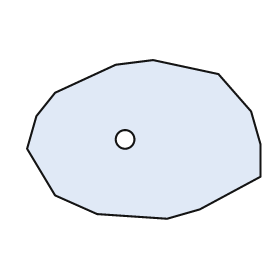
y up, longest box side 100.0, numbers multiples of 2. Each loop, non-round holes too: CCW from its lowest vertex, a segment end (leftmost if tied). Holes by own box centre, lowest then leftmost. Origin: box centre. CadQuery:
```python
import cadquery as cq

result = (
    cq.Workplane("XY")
    .moveTo(10.0, -34.0)
    .lineTo(24.0, -30.0)
    .lineTo(50.0, -16.0)
    .lineTo(50.0, -2.0)
    .lineTo(46.0, 12.0)
    .lineTo(32.0, 28.0)
    .lineTo(4.0, 34.0)
    .lineTo(-12.0, 32.0)
    .lineTo(-38.0, 20.0)
    .lineTo(-46.0, 10.0)
    .lineTo(-50.0, -4.0)
    .lineTo(-38.0, -24.0)
    .lineTo(-20.0, -32.0)
    .close()
    .moveTo(-8.0, 0.0)
    .circle(4.0)
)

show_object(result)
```